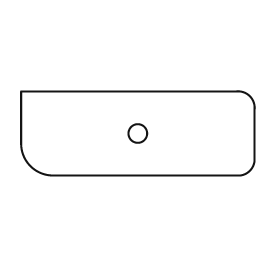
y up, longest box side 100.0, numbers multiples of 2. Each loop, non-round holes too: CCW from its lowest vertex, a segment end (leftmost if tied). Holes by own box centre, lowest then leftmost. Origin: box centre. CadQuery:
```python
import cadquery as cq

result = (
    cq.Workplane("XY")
    .moveTo(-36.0, -18.0)
    .lineTo(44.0, -18.0)
    .threePointArc((48.0, -16.0), (50.0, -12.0))
    .lineTo(50.0, 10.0)
    .threePointArc((48.0, 16.0), (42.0, 18.0))
    .lineTo(-50.0, 18.0)
    .lineTo(-50.0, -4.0)
    .threePointArc((-46.0, -14.0), (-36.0, -18.0))
    .close()
    .moveTo(0.0, 0.0)
    .circle(4.0)
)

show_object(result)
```